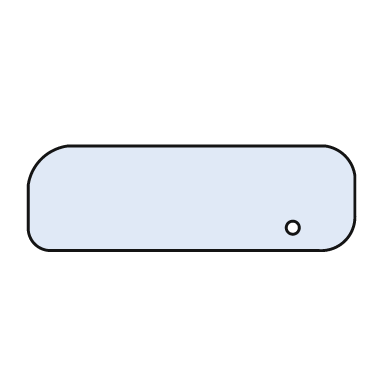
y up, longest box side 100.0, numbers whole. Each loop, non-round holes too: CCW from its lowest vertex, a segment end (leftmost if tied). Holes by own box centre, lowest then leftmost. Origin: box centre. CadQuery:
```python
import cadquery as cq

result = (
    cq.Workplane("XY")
    .moveTo(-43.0, -16.0)
    .lineTo(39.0, -16.0)
    .threePointArc((47.0, -13.0), (50.0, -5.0))
    .lineTo(50.0, 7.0)
    .threePointArc((47.0, 13.0), (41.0, 16.0))
    .lineTo(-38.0, 16.0)
    .threePointArc((-46.0, 12.0), (-50.0, 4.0))
    .lineTo(-50.0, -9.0)
    .threePointArc((-48.0, -14.0), (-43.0, -16.0))
    .close()
    .moveTo(31.0, -9.0)
    .circle(2.0)
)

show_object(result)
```